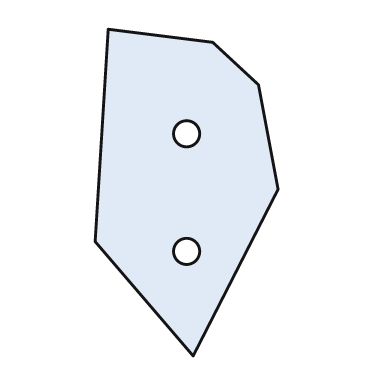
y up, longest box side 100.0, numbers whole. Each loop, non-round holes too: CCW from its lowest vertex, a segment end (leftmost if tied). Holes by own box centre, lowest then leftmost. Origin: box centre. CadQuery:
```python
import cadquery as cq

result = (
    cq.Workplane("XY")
    .moveTo(2.0, -50.0)
    .lineTo(28.0, 1.0)
    .lineTo(22.0, 33.0)
    .lineTo(8.0, 46.0)
    .lineTo(-24.0, 50.0)
    .lineTo(-28.0, -15.0)
    .close()
    .moveTo(0.0, -18.0)
    .circle(4.0)
    .moveTo(0.0, 18.0)
    .circle(4.0)
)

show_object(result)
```